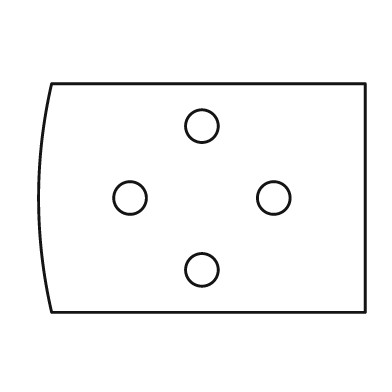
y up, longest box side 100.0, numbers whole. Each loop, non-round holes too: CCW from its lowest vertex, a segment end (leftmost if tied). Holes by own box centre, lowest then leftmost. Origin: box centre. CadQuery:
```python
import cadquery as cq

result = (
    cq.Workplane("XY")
    .moveTo(-46.0, -35.0)
    .lineTo(50.0, -35.0)
    .lineTo(50.0, 35.0)
    .lineTo(-46.0, 35.0)
    .threePointArc((-50.0, 0.0), (-46.0, -35.0))
    .close()
    .moveTo(0.0, -22.0)
    .circle(5.0)
    .moveTo(-22.0, 0.0)
    .circle(5.0)
    .moveTo(22.0, 0.0)
    .circle(5.0)
    .moveTo(0.0, 22.0)
    .circle(5.0)
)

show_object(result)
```